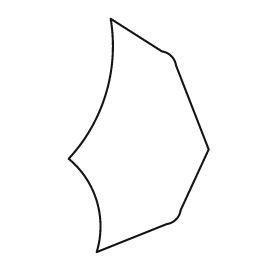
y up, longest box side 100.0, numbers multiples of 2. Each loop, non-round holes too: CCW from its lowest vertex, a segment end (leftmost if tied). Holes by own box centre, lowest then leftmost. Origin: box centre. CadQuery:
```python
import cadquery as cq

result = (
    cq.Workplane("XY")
    .moveTo(-18.0, -50.0)
    .lineTo(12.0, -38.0)
    .threePointArc((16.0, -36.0), (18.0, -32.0))
    .lineTo(30.0, -6.0)
    .lineTo(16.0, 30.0)
    .threePointArc((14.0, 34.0), (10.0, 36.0))
    .lineTo(-12.0, 50.0)
    .threePointArc((-14.0, 18.0), (-30.0, -10.0))
    .threePointArc((-18.0, -28.0), (-18.0, -50.0))
    .close()
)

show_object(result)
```